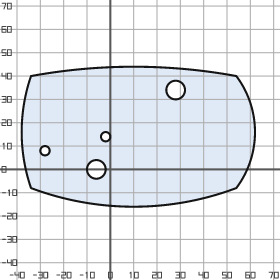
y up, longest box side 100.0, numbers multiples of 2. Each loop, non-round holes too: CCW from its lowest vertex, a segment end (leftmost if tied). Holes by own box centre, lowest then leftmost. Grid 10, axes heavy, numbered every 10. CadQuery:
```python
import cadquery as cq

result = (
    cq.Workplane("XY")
    .moveTo(-34.0, -8.0)
    .threePointArc((10.0, -16.0), (54.0, -8.0))
    .threePointArc((62.0, 16.0), (54.0, 40.0))
    .threePointArc((10.0, 44.0), (-34.0, 40.0))
    .threePointArc((-38.0, 16.0), (-34.0, -8.0))
    .close()
    .moveTo(-6.0, 0.0)
    .circle(4.0)
    .moveTo(-28.0, 8.0)
    .circle(2.0)
    .moveTo(-2.0, 14.0)
    .circle(2.0)
    .moveTo(28.0, 34.0)
    .circle(4.0)
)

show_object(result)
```